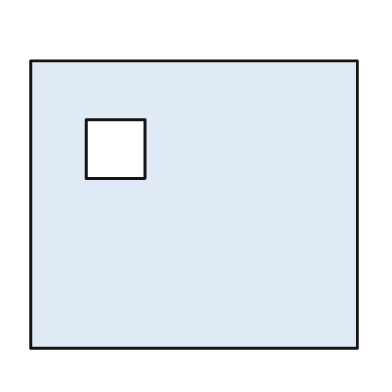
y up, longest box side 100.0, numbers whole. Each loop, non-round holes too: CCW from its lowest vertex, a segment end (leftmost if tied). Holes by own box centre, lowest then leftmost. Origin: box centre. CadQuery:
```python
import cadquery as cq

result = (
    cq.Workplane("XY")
    .moveTo(-50.0, -44.0)
    .lineTo(50.0, -44.0)
    .lineTo(50.0, 44.0)
    .lineTo(-50.0, 44.0)
    .close()
    .moveTo(-33.0, 8.0)
    .lineTo(-15.0, 8.0)
    .lineTo(-15.0, 26.0)
    .lineTo(-33.0, 26.0)
    .close()
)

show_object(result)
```